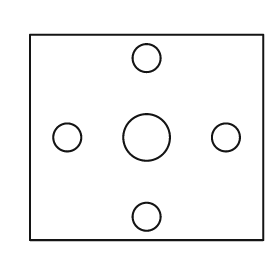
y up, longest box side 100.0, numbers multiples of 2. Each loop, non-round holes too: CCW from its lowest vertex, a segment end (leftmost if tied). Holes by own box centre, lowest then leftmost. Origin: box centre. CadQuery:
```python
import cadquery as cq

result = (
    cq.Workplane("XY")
    .moveTo(-50.0, -44.0)
    .lineTo(50.0, -44.0)
    .lineTo(50.0, 44.0)
    .lineTo(-50.0, 44.0)
    .close()
    .moveTo(0.0, -34.0)
    .circle(6.0)
    .moveTo(-34.0, 0.0)
    .circle(6.0)
    .moveTo(0.0, 0.0)
    .circle(10.0)
    .moveTo(34.0, 0.0)
    .circle(6.0)
    .moveTo(0.0, 34.0)
    .circle(6.0)
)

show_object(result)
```